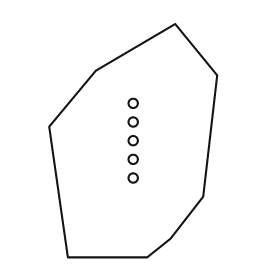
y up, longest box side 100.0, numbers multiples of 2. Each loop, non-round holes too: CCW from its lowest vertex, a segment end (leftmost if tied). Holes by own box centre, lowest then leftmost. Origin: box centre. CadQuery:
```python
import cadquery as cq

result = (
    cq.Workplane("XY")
    .moveTo(-28.0, -50.0)
    .lineTo(6.0, -50.0)
    .lineTo(16.0, -42.0)
    .lineTo(30.0, -24.0)
    .lineTo(36.0, 28.0)
    .lineTo(18.0, 50.0)
    .lineTo(-16.0, 30.0)
    .lineTo(-36.0, 6.0)
    .close()
    .moveTo(0.0, -16.0)
    .circle(2.0)
    .moveTo(0.0, -8.0)
    .circle(2.0)
    .moveTo(0.0, 0.0)
    .circle(2.0)
    .moveTo(0.0, 8.0)
    .circle(2.0)
    .moveTo(0.0, 16.0)
    .circle(2.0)
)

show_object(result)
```